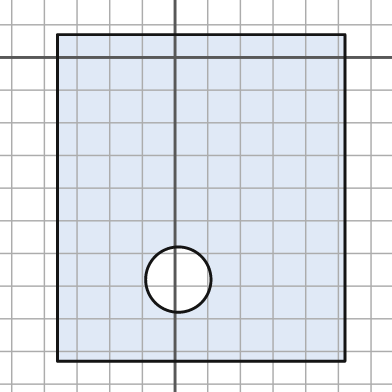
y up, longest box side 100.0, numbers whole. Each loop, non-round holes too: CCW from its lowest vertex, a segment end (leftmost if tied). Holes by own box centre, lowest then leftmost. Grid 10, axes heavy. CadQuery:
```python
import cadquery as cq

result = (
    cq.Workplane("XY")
    .moveTo(-36.0, -93.0)
    .lineTo(52.0, -93.0)
    .lineTo(52.0, 7.0)
    .lineTo(-36.0, 7.0)
    .close()
    .moveTo(1.0, -68.0)
    .circle(10.0)
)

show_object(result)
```